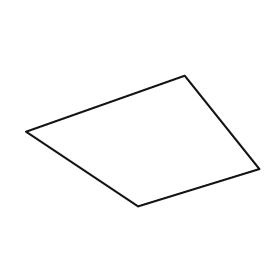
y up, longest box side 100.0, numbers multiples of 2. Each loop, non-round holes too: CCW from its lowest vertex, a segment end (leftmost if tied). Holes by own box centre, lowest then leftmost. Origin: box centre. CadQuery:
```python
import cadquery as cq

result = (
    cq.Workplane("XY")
    .moveTo(-2.0, -28.0)
    .lineTo(50.0, -12.0)
    .lineTo(18.0, 28.0)
    .lineTo(-50.0, 4.0)
    .close()
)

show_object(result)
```